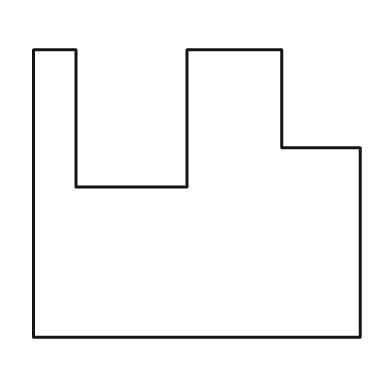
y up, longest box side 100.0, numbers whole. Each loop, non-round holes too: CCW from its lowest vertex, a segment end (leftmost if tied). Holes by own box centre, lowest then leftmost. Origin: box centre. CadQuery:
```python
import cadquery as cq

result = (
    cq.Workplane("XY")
    .moveTo(-50.0, -44.0)
    .lineTo(50.0, -44.0)
    .lineTo(50.0, 14.0)
    .lineTo(26.0, 14.0)
    .lineTo(26.0, 44.0)
    .lineTo(-3.0, 44.0)
    .lineTo(-3.0, 2.0)
    .lineTo(-37.0, 2.0)
    .lineTo(-37.0, 44.0)
    .lineTo(-50.0, 44.0)
    .close()
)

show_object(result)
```